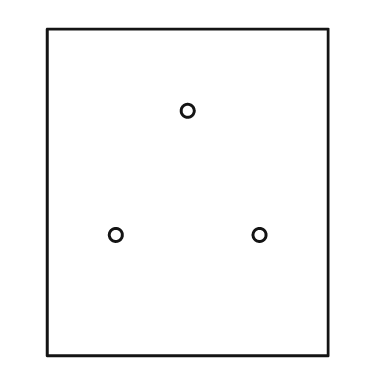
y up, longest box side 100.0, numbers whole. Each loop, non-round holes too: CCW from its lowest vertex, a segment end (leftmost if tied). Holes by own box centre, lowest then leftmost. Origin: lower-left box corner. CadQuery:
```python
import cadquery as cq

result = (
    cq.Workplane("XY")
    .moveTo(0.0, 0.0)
    .lineTo(86.0, 0.0)
    .lineTo(86.0, 100.0)
    .lineTo(0.0, 100.0)
    .close()
    .moveTo(21.0, 37.0)
    .circle(2.0)
    .moveTo(65.0, 37.0)
    .circle(2.0)
    .moveTo(43.0, 75.0)
    .circle(2.0)
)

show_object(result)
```